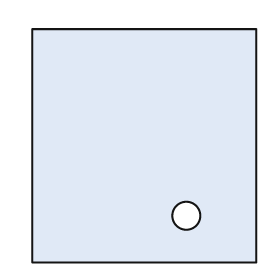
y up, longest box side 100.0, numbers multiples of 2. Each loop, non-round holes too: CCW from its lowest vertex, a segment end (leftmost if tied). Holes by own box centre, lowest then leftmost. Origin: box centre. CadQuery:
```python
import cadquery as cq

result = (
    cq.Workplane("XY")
    .moveTo(-48.0, -50.0)
    .lineTo(48.0, -50.0)
    .lineTo(48.0, 50.0)
    .lineTo(-48.0, 50.0)
    .close()
    .moveTo(18.0, -30.0)
    .circle(6.0)
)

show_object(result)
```